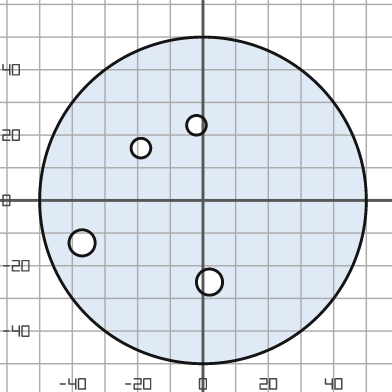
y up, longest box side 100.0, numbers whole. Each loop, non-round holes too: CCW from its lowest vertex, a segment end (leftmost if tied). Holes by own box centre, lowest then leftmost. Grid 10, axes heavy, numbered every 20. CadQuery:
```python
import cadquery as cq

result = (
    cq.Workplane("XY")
    .moveTo(0.0, 0.0)
    .circle(50.0)
    .moveTo(2.0, -25.0)
    .circle(4.0)
    .moveTo(-37.0, -13.0)
    .circle(4.0)
    .moveTo(-19.0, 16.0)
    .circle(3.0)
    .moveTo(-2.0, 23.0)
    .circle(3.0)
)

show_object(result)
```